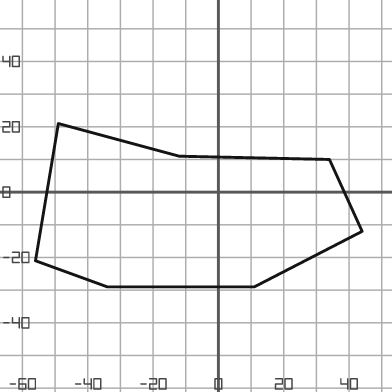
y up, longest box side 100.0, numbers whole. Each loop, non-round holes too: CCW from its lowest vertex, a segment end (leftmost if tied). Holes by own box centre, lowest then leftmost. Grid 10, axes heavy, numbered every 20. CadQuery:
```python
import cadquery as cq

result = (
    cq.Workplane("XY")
    .moveTo(-34.0, -29.0)
    .lineTo(11.0, -29.0)
    .lineTo(44.0, -12.0)
    .lineTo(34.0, 10.0)
    .lineTo(-12.0, 11.0)
    .lineTo(-49.0, 21.0)
    .lineTo(-56.0, -21.0)
    .close()
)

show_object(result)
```